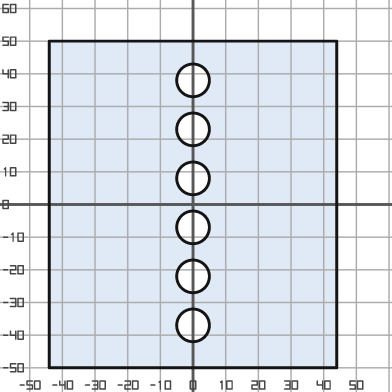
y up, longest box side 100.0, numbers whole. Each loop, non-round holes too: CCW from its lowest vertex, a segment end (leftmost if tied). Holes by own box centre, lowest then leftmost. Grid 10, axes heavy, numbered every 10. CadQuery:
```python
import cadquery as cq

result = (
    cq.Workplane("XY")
    .moveTo(-44.0, -50.0)
    .lineTo(44.0, -50.0)
    .lineTo(44.0, 50.0)
    .lineTo(-44.0, 50.0)
    .close()
    .moveTo(0.0, -37.0)
    .circle(5.0)
    .moveTo(0.0, -22.0)
    .circle(5.0)
    .moveTo(0.0, -7.0)
    .circle(5.0)
    .moveTo(0.0, 8.0)
    .circle(5.0)
    .moveTo(0.0, 23.0)
    .circle(5.0)
    .moveTo(0.0, 38.0)
    .circle(5.0)
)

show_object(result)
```